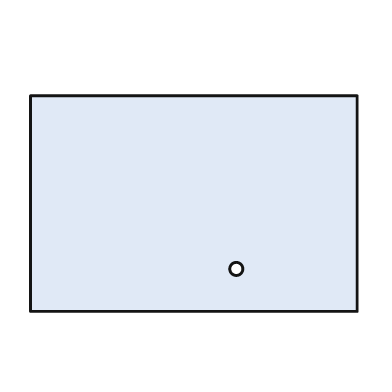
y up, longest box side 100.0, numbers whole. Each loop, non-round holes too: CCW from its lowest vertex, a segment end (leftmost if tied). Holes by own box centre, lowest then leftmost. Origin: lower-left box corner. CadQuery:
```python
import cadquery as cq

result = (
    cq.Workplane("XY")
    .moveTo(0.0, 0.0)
    .lineTo(100.0, 0.0)
    .lineTo(100.0, 66.0)
    .lineTo(0.0, 66.0)
    .close()
    .moveTo(63.0, 13.0)
    .circle(2.0)
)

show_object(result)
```